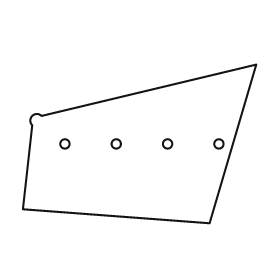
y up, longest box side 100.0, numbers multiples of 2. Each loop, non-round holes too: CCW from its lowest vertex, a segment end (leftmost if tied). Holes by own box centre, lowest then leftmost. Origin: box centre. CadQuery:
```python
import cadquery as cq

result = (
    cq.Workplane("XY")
    .moveTo(30.0, -34.0)
    .lineTo(50.0, 34.0)
    .lineTo(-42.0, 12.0)
    .threePointArc((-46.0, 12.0), (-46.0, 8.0))
    .lineTo(-50.0, -28.0)
    .close()
    .moveTo(-32.0, 0.0)
    .circle(2.0)
    .moveTo(-10.0, 0.0)
    .circle(2.0)
    .moveTo(12.0, 0.0)
    .circle(2.0)
    .moveTo(34.0, 0.0)
    .circle(2.0)
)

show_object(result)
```